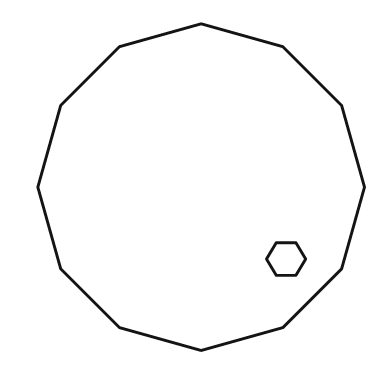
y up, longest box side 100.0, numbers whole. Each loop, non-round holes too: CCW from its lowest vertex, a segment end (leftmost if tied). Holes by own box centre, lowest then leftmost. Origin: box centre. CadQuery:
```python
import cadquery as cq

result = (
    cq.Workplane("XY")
    .moveTo(0.0, -50.0)
    .lineTo(25.0, -43.0)
    .lineTo(43.0, -25.0)
    .lineTo(50.0, 0.0)
    .lineTo(43.0, 25.0)
    .lineTo(25.0, 43.0)
    .lineTo(0.0, 50.0)
    .lineTo(-25.0, 43.0)
    .lineTo(-43.0, 25.0)
    .lineTo(-50.0, 0.0)
    .lineTo(-43.0, -25.0)
    .lineTo(-25.0, -43.0)
    .close()
    .moveTo(23.0, -27.0)
    .lineTo(29.0, -27.0)
    .lineTo(32.0, -22.0)
    .lineTo(29.0, -17.0)
    .lineTo(23.0, -17.0)
    .lineTo(20.0, -22.0)
    .close()
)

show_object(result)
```